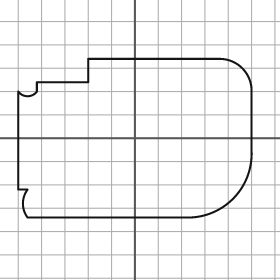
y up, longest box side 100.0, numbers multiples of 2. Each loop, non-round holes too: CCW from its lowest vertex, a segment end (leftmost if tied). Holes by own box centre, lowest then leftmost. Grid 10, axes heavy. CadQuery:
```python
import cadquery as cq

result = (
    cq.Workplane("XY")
    .moveTo(-46.0, -34.0)
    .lineTo(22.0, -34.0)
    .threePointArc((42.0, -26.0), (50.0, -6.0))
    .lineTo(50.0, 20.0)
    .threePointArc((46.0, 30.0), (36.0, 34.0))
    .lineTo(-20.0, 34.0)
    .lineTo(-20.0, 24.0)
    .lineTo(-42.0, 24.0)
    .lineTo(-42.0, 20.0)
    .threePointArc((-46.0, 18.0), (-50.0, 20.0))
    .lineTo(-50.0, -22.0)
    .lineTo(-46.0, -22.0)
    .threePointArc((-48.0, -28.0), (-46.0, -34.0))
    .close()
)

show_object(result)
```